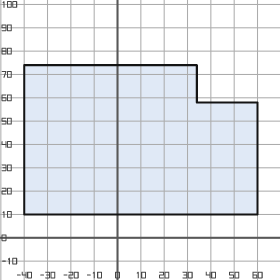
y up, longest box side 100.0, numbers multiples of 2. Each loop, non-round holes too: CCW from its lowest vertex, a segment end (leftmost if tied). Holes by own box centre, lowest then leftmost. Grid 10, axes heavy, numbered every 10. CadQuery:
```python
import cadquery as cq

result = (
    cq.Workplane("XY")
    .moveTo(-40.0, 10.0)
    .lineTo(60.0, 10.0)
    .lineTo(60.0, 58.0)
    .lineTo(34.0, 58.0)
    .lineTo(34.0, 74.0)
    .lineTo(-40.0, 74.0)
    .close()
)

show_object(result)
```